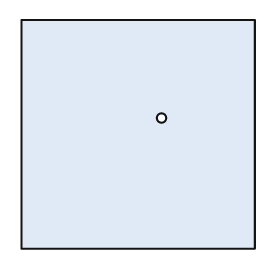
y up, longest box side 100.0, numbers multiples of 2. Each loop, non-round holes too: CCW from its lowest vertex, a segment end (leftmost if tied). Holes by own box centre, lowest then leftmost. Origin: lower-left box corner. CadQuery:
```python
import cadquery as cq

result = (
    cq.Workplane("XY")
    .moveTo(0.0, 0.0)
    .lineTo(100.0, 0.0)
    .lineTo(100.0, 98.0)
    .lineTo(0.0, 98.0)
    .close()
    .moveTo(60.0, 56.0)
    .circle(2.0)
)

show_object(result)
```